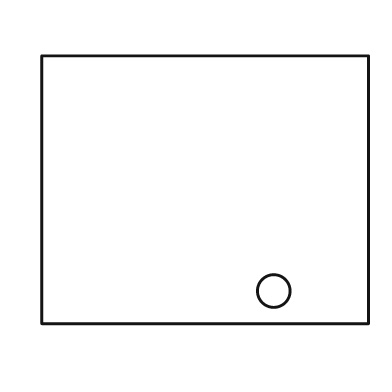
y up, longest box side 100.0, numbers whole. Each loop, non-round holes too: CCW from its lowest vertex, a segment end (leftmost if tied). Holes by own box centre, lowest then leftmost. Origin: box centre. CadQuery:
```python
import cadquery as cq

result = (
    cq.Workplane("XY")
    .moveTo(-50.0, -41.0)
    .lineTo(50.0, -41.0)
    .lineTo(50.0, 41.0)
    .lineTo(-50.0, 41.0)
    .close()
    .moveTo(21.0, -31.0)
    .circle(5.0)
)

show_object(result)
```